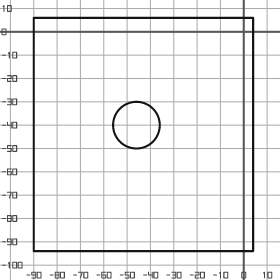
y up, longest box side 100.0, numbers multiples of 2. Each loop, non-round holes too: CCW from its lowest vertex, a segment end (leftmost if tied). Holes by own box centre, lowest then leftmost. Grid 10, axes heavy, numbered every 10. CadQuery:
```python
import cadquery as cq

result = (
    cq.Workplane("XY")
    .moveTo(-90.0, -94.0)
    .lineTo(4.0, -94.0)
    .lineTo(4.0, 6.0)
    .lineTo(-90.0, 6.0)
    .close()
    .moveTo(-46.0, -40.0)
    .circle(10.0)
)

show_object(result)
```